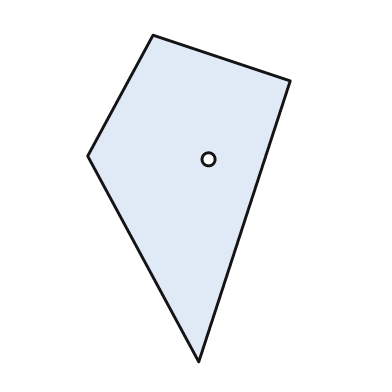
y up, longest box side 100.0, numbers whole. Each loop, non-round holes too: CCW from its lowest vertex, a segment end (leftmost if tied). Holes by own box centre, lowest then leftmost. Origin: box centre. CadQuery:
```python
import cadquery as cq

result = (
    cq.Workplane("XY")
    .moveTo(3.0, -50.0)
    .lineTo(31.0, 36.0)
    .lineTo(-11.0, 50.0)
    .lineTo(-31.0, 13.0)
    .close()
    .moveTo(6.0, 12.0)
    .circle(2.0)
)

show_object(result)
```